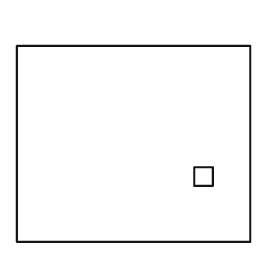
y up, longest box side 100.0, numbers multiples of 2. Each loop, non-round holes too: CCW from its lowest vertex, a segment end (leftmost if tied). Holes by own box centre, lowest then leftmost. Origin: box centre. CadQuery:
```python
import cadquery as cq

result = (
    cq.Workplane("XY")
    .moveTo(-50.0, -42.0)
    .lineTo(50.0, -42.0)
    .lineTo(50.0, 42.0)
    .lineTo(-50.0, 42.0)
    .close()
    .moveTo(26.0, -18.0)
    .lineTo(34.0, -18.0)
    .lineTo(34.0, -10.0)
    .lineTo(26.0, -10.0)
    .close()
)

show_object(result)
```